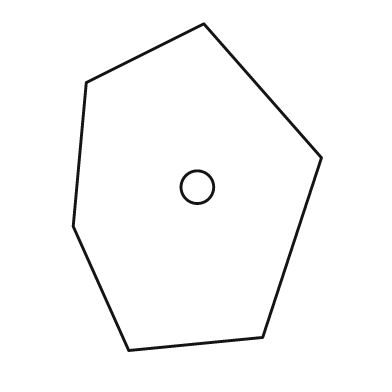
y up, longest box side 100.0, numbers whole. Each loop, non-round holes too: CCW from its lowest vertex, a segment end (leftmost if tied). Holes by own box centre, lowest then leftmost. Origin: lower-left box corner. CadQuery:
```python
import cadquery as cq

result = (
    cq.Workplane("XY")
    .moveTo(17.0, 0.0)
    .lineTo(58.0, 4.0)
    .lineTo(76.0, 59.0)
    .lineTo(40.0, 100.0)
    .lineTo(4.0, 82.0)
    .lineTo(0.0, 38.0)
    .close()
    .moveTo(38.0, 50.0)
    .circle(5.0)
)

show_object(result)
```